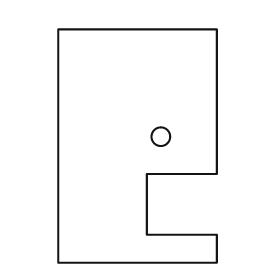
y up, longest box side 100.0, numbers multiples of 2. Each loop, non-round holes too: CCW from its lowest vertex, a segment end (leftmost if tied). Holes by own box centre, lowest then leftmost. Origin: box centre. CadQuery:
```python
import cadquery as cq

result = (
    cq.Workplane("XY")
    .moveTo(-34.0, -50.0)
    .lineTo(34.0, -50.0)
    .lineTo(34.0, -38.0)
    .lineTo(4.0, -38.0)
    .lineTo(4.0, -12.0)
    .lineTo(34.0, -12.0)
    .lineTo(34.0, 50.0)
    .lineTo(-34.0, 50.0)
    .close()
    .moveTo(10.0, 4.0)
    .circle(4.0)
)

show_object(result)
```